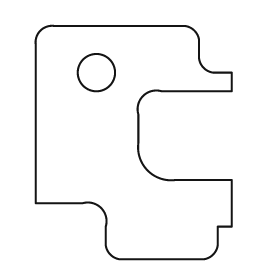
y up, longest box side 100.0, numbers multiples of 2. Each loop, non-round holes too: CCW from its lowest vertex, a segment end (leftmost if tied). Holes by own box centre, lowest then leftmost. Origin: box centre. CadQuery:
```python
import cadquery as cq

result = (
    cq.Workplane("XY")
    .moveTo(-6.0, -50.0)
    .lineTo(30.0, -50.0)
    .threePointArc((34.0, -48.0), (36.0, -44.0))
    .lineTo(36.0, -36.0)
    .lineTo(42.0, -36.0)
    .lineTo(42.0, -16.0)
    .lineTo(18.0, -16.0)
    .threePointArc((6.0, -12.0), (2.0, 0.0))
    .lineTo(2.0, 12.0)
    .threePointArc((4.0, 20.0), (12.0, 22.0))
    .lineTo(42.0, 22.0)
    .lineTo(42.0, 30.0)
    .lineTo(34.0, 30.0)
    .threePointArc((30.0, 32.0), (28.0, 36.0))
    .lineTo(28.0, 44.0)
    .threePointArc((26.0, 48.0), (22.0, 50.0))
    .lineTo(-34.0, 50.0)
    .threePointArc((-40.0, 48.0), (-42.0, 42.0))
    .lineTo(-42.0, -26.0)
    .lineTo(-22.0, -26.0)
    .threePointArc((-14.0, -28.0), (-12.0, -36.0))
    .lineTo(-12.0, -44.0)
    .threePointArc((-10.0, -48.0), (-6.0, -50.0))
    .close()
    .moveTo(-16.0, 30.0)
    .circle(8.0)
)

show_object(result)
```